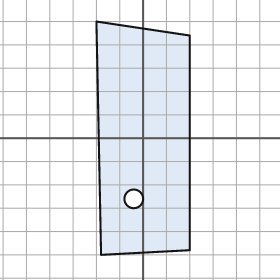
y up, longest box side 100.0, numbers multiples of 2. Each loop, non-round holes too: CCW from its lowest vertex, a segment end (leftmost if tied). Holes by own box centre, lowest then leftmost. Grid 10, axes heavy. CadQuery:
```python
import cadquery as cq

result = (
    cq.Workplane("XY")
    .moveTo(-18.0, -50.0)
    .lineTo(20.0, -48.0)
    .lineTo(20.0, 44.0)
    .lineTo(-20.0, 50.0)
    .close()
    .moveTo(-4.0, -26.0)
    .circle(4.0)
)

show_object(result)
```